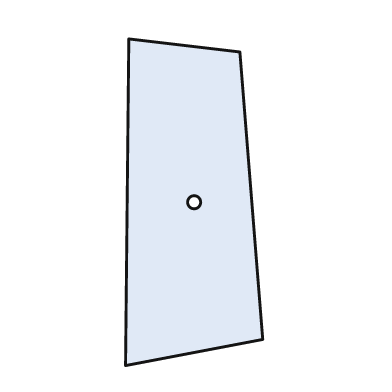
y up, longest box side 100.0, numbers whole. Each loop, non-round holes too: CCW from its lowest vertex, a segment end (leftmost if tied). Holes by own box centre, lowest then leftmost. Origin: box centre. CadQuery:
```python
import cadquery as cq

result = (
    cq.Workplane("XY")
    .moveTo(-21.0, -50.0)
    .lineTo(21.0, -42.0)
    .lineTo(14.0, 46.0)
    .lineTo(-20.0, 50.0)
    .close()
    .moveTo(0.0, 0.0)
    .circle(2.0)
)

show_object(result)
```